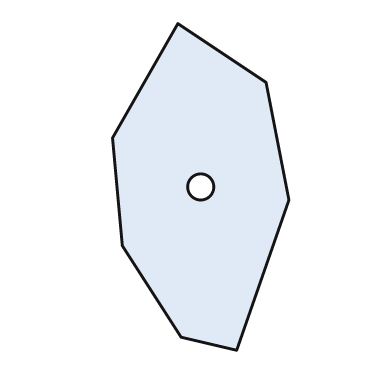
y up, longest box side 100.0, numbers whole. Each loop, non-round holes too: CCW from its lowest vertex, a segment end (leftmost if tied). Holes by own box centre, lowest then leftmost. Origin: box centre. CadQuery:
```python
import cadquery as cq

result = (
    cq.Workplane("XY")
    .moveTo(11.0, -50.0)
    .lineTo(27.0, -4.0)
    .lineTo(20.0, 32.0)
    .lineTo(-7.0, 50.0)
    .lineTo(-27.0, 15.0)
    .lineTo(-24.0, -18.0)
    .lineTo(-6.0, -46.0)
    .close()
    .moveTo(0.0, 0.0)
    .circle(4.0)
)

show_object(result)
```